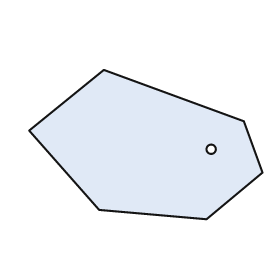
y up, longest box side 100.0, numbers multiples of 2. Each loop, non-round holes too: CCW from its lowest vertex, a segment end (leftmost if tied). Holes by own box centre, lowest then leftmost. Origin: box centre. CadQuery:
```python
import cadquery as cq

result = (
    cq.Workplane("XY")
    .moveTo(26.0, -32.0)
    .lineTo(50.0, -12.0)
    .lineTo(42.0, 10.0)
    .lineTo(-18.0, 32.0)
    .lineTo(-50.0, 6.0)
    .lineTo(-20.0, -28.0)
    .close()
    .moveTo(28.0, -2.0)
    .circle(2.0)
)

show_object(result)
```